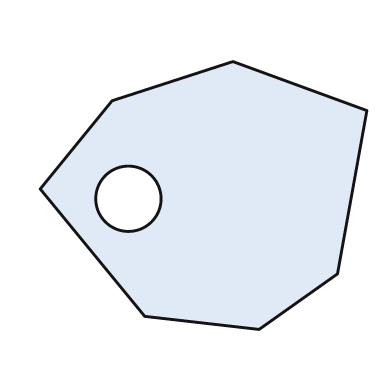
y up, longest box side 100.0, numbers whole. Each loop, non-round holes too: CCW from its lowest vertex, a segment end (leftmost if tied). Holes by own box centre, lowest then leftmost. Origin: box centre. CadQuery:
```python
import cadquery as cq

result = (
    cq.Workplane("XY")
    .moveTo(17.0, -41.0)
    .lineTo(41.0, -24.0)
    .lineTo(50.0, 26.0)
    .lineTo(9.0, 41.0)
    .lineTo(-28.0, 29.0)
    .lineTo(-50.0, 2.0)
    .lineTo(-18.0, -37.0)
    .close()
    .moveTo(-23.0, -1.0)
    .circle(10.0)
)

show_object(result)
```